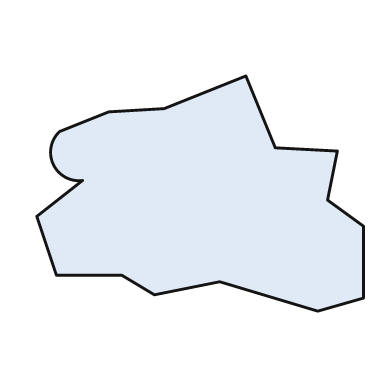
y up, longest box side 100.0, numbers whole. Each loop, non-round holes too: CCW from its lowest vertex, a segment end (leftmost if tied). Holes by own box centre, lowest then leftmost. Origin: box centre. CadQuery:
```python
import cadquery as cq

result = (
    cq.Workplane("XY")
    .moveTo(36.0, -36.0)
    .lineTo(50.0, -32.0)
    .lineTo(50.0, -10.0)
    .lineTo(39.0, -2.0)
    .lineTo(42.0, 13.0)
    .lineTo(23.0, 14.0)
    .lineTo(14.0, 36.0)
    .lineTo(-11.0, 26.0)
    .lineTo(-28.0, 25.0)
    .lineTo(-43.0, 19.0)
    .threePointArc((-45.0, 9.0), (-36.0, 4.0))
    .lineTo(-50.0, -7.0)
    .lineTo(-44.0, -25.0)
    .lineTo(-24.0, -25.0)
    .lineTo(-14.0, -31.0)
    .lineTo(6.0, -27.0)
    .close()
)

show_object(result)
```